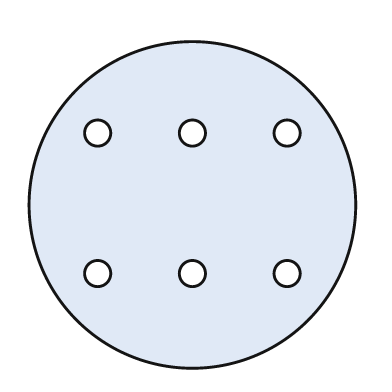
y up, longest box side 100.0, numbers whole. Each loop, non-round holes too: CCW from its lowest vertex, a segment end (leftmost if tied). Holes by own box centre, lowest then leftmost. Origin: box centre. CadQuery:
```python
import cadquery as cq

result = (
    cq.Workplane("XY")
    .moveTo(0.0, 0.0)
    .circle(50.0)
    .moveTo(-29.0, -21.0)
    .circle(4.0)
    .moveTo(0.0, -21.0)
    .circle(4.0)
    .moveTo(29.0, -21.0)
    .circle(4.0)
    .moveTo(-29.0, 22.0)
    .circle(4.0)
    .moveTo(0.0, 22.0)
    .circle(4.0)
    .moveTo(29.0, 22.0)
    .circle(4.0)
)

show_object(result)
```